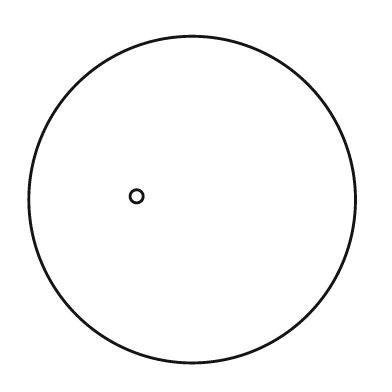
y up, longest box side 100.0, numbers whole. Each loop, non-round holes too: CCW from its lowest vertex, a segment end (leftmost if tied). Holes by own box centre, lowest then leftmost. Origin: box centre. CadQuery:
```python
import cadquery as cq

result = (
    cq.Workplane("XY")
    .moveTo(0.0, 0.0)
    .circle(50.0)
    .moveTo(-17.0, 1.0)
    .circle(2.0)
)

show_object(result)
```